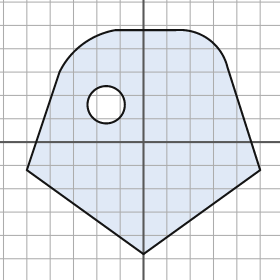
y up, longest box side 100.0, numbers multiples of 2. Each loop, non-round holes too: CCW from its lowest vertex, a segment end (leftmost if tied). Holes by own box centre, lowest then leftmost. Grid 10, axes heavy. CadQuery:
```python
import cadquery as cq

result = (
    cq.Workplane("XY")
    .moveTo(0.0, -48.0)
    .lineTo(50.0, -12.0)
    .lineTo(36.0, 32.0)
    .threePointArc((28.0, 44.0), (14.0, 48.0))
    .lineTo(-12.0, 48.0)
    .threePointArc((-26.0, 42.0), (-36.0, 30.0))
    .lineTo(-50.0, -12.0)
    .close()
    .moveTo(-16.0, 16.0)
    .circle(8.0)
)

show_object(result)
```